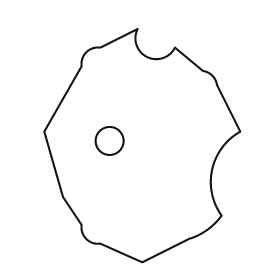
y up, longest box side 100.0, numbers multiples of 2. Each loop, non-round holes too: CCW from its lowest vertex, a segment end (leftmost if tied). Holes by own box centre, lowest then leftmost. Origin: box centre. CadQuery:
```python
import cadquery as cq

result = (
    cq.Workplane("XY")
    .moveTo(0.0, -50.0)
    .lineTo(20.0, -40.0)
    .threePointArc((28.0, -36.0), (34.0, -30.0))
    .threePointArc((30.0, -10.0), (42.0, 6.0))
    .lineTo(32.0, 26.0)
    .threePointArc((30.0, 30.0), (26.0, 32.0))
    .lineTo(14.0, 42.0)
    .threePointArc((2.0, 38.0), (-2.0, 50.0))
    .lineTo(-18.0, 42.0)
    .threePointArc((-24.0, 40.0), (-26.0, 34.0))
    .lineTo(-42.0, 6.0)
    .lineTo(-34.0, -22.0)
    .lineTo(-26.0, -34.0)
    .threePointArc((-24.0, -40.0), (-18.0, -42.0))
    .close()
    .moveTo(-14.0, 2.0)
    .circle(6.0)
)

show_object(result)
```